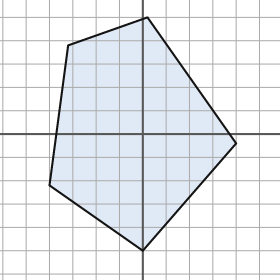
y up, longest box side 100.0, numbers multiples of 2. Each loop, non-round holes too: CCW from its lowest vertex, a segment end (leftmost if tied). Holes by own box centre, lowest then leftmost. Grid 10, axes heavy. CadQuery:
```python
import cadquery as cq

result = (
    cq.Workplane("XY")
    .moveTo(0.0, -50.0)
    .lineTo(40.0, -4.0)
    .lineTo(2.0, 50.0)
    .lineTo(-32.0, 38.0)
    .lineTo(-40.0, -22.0)
    .close()
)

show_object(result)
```